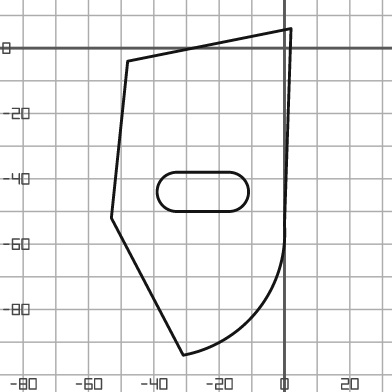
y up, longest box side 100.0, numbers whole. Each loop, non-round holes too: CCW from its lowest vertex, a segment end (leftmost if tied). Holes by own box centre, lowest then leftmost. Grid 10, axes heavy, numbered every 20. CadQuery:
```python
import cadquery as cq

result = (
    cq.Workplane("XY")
    .moveTo(-31.0, -94.0)
    .threePointArc((-8.0, -80.0), (0.0, -54.0))
    .lineTo(2.0, 6.0)
    .lineTo(-48.0, -4.0)
    .lineTo(-53.0, -52.0)
    .close()
    .moveTo(-33.0, -50.0)
    .lineTo(-17.0, -50.0)
    .threePointArc((-11.0, -44.0), (-17.0, -38.0))
    .lineTo(-33.0, -38.0)
    .threePointArc((-39.0, -44.0), (-33.0, -50.0))
    .close()
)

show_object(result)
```